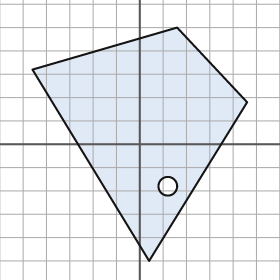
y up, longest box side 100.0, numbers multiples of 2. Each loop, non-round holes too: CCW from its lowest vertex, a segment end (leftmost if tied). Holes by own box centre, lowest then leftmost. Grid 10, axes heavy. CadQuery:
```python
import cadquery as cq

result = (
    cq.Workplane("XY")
    .moveTo(4.0, -50.0)
    .lineTo(46.0, 18.0)
    .lineTo(16.0, 50.0)
    .lineTo(-46.0, 32.0)
    .close()
    .moveTo(12.0, -18.0)
    .circle(4.0)
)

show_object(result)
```